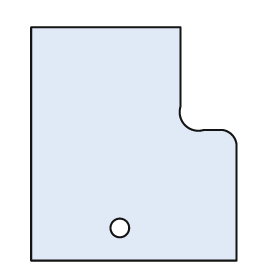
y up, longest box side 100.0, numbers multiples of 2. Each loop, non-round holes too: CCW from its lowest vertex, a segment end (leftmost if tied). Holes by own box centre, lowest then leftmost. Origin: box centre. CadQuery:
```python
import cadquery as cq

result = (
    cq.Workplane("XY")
    .moveTo(-44.0, -50.0)
    .lineTo(44.0, -50.0)
    .lineTo(44.0, 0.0)
    .threePointArc((42.0, 4.0), (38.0, 6.0))
    .lineTo(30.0, 6.0)
    .threePointArc((22.0, 8.0), (20.0, 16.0))
    .lineTo(20.0, 50.0)
    .lineTo(-44.0, 50.0)
    .close()
    .moveTo(-6.0, -36.0)
    .circle(4.0)
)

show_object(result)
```